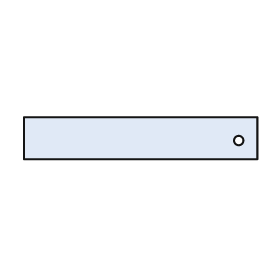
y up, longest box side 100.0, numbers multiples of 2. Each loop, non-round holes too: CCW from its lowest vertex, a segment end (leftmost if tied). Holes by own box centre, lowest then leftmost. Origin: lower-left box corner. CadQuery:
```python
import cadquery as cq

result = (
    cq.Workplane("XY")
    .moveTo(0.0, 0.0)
    .lineTo(100.0, 0.0)
    .lineTo(100.0, 18.0)
    .lineTo(0.0, 18.0)
    .close()
    .moveTo(92.0, 8.0)
    .circle(2.0)
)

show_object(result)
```